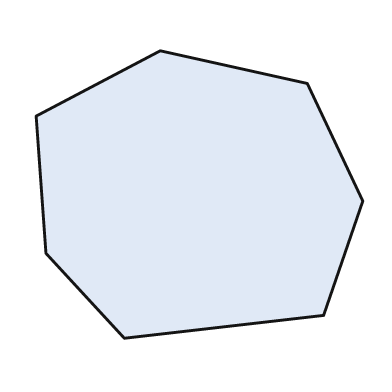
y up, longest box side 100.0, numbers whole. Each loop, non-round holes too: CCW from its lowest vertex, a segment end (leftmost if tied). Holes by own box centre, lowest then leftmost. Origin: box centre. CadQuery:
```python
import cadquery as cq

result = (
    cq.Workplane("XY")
    .moveTo(-23.0, -44.0)
    .lineTo(38.0, -37.0)
    .lineTo(50.0, -2.0)
    .lineTo(33.0, 34.0)
    .lineTo(-12.0, 44.0)
    .lineTo(-50.0, 24.0)
    .lineTo(-47.0, -18.0)
    .close()
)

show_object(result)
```